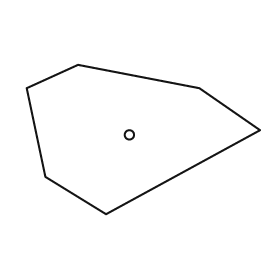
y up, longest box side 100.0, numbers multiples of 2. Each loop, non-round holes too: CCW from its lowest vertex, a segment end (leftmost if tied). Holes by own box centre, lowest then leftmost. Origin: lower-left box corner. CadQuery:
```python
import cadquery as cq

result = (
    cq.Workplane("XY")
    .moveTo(34.0, 0.0)
    .lineTo(100.0, 36.0)
    .lineTo(74.0, 54.0)
    .lineTo(22.0, 64.0)
    .lineTo(0.0, 54.0)
    .lineTo(8.0, 16.0)
    .close()
    .moveTo(44.0, 34.0)
    .circle(2.0)
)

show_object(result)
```